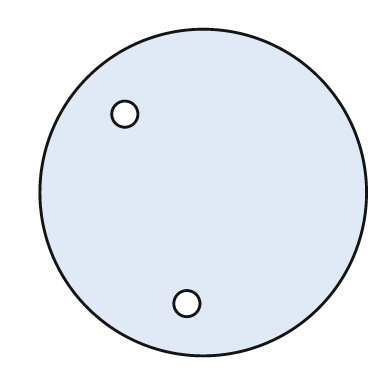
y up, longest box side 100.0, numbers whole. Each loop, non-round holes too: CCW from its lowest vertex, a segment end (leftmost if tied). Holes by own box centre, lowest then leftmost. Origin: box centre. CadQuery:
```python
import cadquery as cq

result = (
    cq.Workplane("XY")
    .moveTo(0.0, 0.0)
    .circle(50.0)
    .moveTo(-5.0, -34.0)
    .circle(4.0)
    .moveTo(-24.0, 24.0)
    .circle(4.0)
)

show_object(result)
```